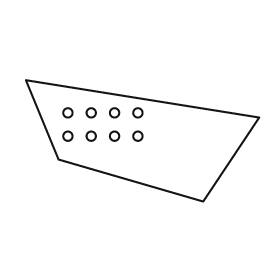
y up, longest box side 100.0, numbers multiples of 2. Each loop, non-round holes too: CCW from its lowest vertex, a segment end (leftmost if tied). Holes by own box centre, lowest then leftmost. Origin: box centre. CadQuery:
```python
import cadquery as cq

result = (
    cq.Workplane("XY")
    .moveTo(26.0, -26.0)
    .lineTo(50.0, 10.0)
    .lineTo(-50.0, 26.0)
    .lineTo(-36.0, -8.0)
    .close()
    .moveTo(-32.0, 2.0)
    .circle(2.0)
    .moveTo(-22.0, 2.0)
    .circle(2.0)
    .moveTo(-12.0, 2.0)
    .circle(2.0)
    .moveTo(-2.0, 2.0)
    .circle(2.0)
    .moveTo(-32.0, 12.0)
    .circle(2.0)
    .moveTo(-22.0, 12.0)
    .circle(2.0)
    .moveTo(-12.0, 12.0)
    .circle(2.0)
    .moveTo(-2.0, 12.0)
    .circle(2.0)
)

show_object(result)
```